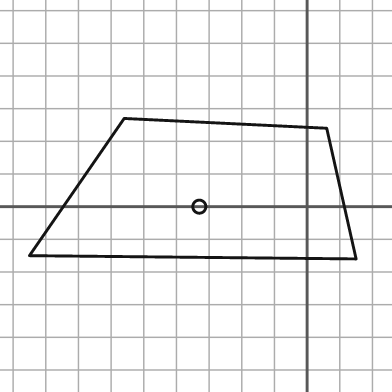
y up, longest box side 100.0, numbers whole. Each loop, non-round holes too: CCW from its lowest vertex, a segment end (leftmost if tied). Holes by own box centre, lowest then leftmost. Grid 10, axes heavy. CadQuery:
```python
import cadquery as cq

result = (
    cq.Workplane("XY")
    .moveTo(15.0, -16.0)
    .lineTo(6.0, 24.0)
    .lineTo(-56.0, 27.0)
    .lineTo(-85.0, -15.0)
    .close()
    .moveTo(-33.0, 0.0)
    .circle(2.0)
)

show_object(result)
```